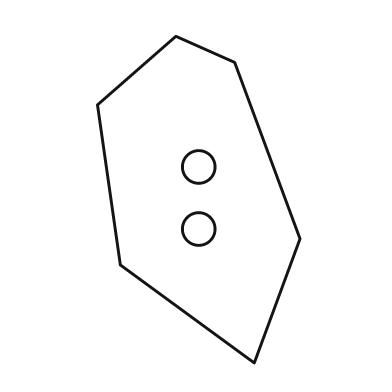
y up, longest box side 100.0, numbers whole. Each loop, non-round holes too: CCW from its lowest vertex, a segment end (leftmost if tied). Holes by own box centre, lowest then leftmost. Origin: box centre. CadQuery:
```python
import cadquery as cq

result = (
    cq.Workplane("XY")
    .moveTo(17.0, -50.0)
    .lineTo(31.0, -12.0)
    .lineTo(11.0, 42.0)
    .lineTo(-7.0, 50.0)
    .lineTo(-31.0, 29.0)
    .lineTo(-24.0, -20.0)
    .close()
    .moveTo(0.0, -9.0)
    .circle(5.0)
    .moveTo(0.0, 10.0)
    .circle(5.0)
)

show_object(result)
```